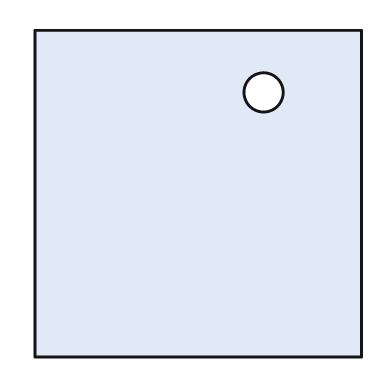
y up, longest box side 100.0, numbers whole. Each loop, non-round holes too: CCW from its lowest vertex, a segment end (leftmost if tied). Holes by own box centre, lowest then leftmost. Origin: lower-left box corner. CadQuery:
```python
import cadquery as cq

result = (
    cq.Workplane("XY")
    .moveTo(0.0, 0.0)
    .lineTo(100.0, 0.0)
    .lineTo(100.0, 100.0)
    .lineTo(0.0, 100.0)
    .close()
    .moveTo(70.0, 81.0)
    .circle(6.0)
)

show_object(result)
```